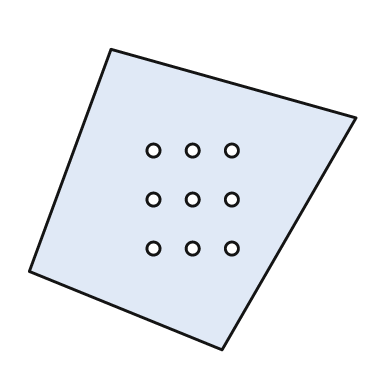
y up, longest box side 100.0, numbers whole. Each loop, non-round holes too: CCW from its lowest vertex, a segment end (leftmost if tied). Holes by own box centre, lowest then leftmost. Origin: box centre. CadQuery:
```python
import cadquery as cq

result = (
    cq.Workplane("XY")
    .moveTo(9.0, -46.0)
    .lineTo(50.0, 25.0)
    .lineTo(-25.0, 46.0)
    .lineTo(-50.0, -22.0)
    .close()
    .moveTo(-12.0, -15.0)
    .circle(2.0)
    .moveTo(0.0, -15.0)
    .circle(2.0)
    .moveTo(12.0, -15.0)
    .circle(2.0)
    .moveTo(-12.0, 0.0)
    .circle(2.0)
    .moveTo(0.0, 0.0)
    .circle(2.0)
    .moveTo(12.0, 0.0)
    .circle(2.0)
    .moveTo(-12.0, 15.0)
    .circle(2.0)
    .moveTo(0.0, 15.0)
    .circle(2.0)
    .moveTo(12.0, 15.0)
    .circle(2.0)
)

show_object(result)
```